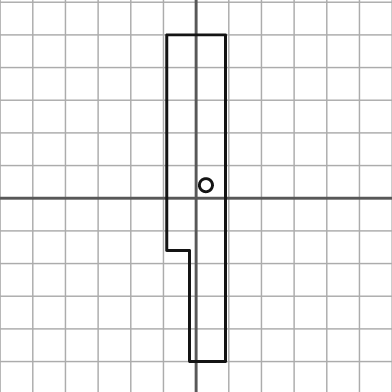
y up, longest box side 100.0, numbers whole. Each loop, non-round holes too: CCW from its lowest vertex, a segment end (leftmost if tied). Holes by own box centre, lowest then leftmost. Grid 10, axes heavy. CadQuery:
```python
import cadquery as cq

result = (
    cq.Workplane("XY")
    .moveTo(-2.0, -50.0)
    .lineTo(9.0, -50.0)
    .lineTo(9.0, 50.0)
    .lineTo(-9.0, 50.0)
    .lineTo(-9.0, -16.0)
    .lineTo(-2.0, -16.0)
    .close()
    .moveTo(3.0, 4.0)
    .circle(2.0)
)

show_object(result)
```